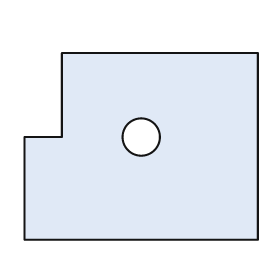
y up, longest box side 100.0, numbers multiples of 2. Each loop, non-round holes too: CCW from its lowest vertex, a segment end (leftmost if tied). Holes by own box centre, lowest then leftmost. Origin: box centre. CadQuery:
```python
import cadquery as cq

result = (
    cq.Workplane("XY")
    .moveTo(-50.0, -40.0)
    .lineTo(50.0, -40.0)
    .lineTo(50.0, 40.0)
    .lineTo(-34.0, 40.0)
    .lineTo(-34.0, 4.0)
    .lineTo(-50.0, 4.0)
    .close()
    .moveTo(0.0, 4.0)
    .circle(8.0)
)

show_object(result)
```